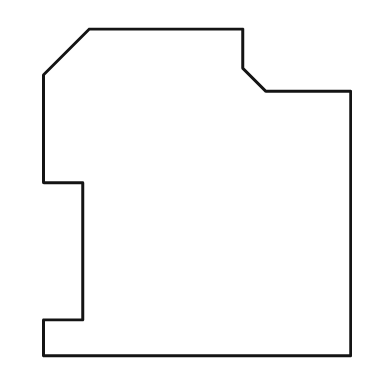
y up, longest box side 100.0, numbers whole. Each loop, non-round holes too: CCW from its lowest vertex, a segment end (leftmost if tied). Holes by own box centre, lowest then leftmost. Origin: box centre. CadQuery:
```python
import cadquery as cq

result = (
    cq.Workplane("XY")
    .moveTo(-47.0, -50.0)
    .lineTo(47.0, -50.0)
    .lineTo(47.0, 31.0)
    .lineTo(21.0, 31.0)
    .lineTo(14.0, 38.0)
    .lineTo(14.0, 50.0)
    .lineTo(-33.0, 50.0)
    .lineTo(-47.0, 36.0)
    .lineTo(-47.0, 3.0)
    .lineTo(-35.0, 3.0)
    .lineTo(-35.0, -39.0)
    .lineTo(-47.0, -39.0)
    .close()
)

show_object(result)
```